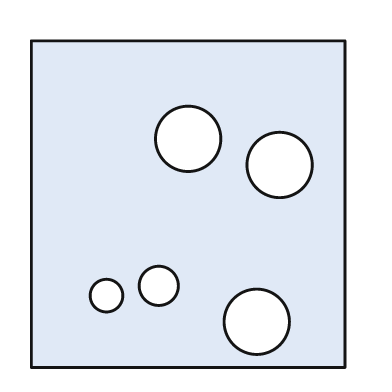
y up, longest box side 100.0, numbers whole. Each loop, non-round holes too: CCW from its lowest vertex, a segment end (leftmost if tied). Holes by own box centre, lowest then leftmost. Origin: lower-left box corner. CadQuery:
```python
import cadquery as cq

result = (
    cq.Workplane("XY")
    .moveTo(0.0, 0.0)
    .lineTo(96.0, 0.0)
    .lineTo(96.0, 100.0)
    .lineTo(0.0, 100.0)
    .close()
    .moveTo(69.0, 14.0)
    .circle(10.0)
    .moveTo(23.0, 22.0)
    .circle(5.0)
    .moveTo(39.0, 25.0)
    .circle(6.0)
    .moveTo(76.0, 62.0)
    .circle(10.0)
    .moveTo(48.0, 70.0)
    .circle(10.0)
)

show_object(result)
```